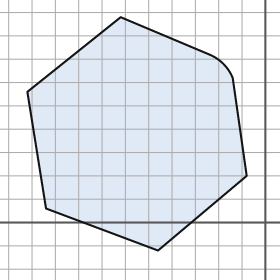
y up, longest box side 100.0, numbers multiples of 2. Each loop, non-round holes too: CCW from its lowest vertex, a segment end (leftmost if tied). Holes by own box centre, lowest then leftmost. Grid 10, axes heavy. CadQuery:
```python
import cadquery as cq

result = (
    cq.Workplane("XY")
    .moveTo(-46.0, -12.0)
    .lineTo(-8.0, 20.0)
    .lineTo(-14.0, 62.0)
    .threePointArc((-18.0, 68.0), (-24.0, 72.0))
    .lineTo(-62.0, 88.0)
    .lineTo(-102.0, 56.0)
    .lineTo(-94.0, 6.0)
    .close()
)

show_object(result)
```